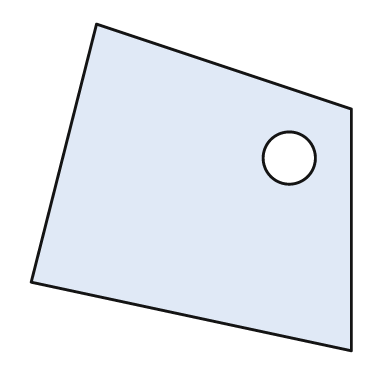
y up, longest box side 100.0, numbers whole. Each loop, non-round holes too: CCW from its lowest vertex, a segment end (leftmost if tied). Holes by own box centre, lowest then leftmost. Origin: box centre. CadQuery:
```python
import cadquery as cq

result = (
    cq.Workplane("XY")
    .moveTo(49.0, -50.0)
    .lineTo(49.0, 24.0)
    .lineTo(-29.0, 50.0)
    .lineTo(-49.0, -29.0)
    .close()
    .moveTo(30.0, 9.0)
    .circle(8.0)
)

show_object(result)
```